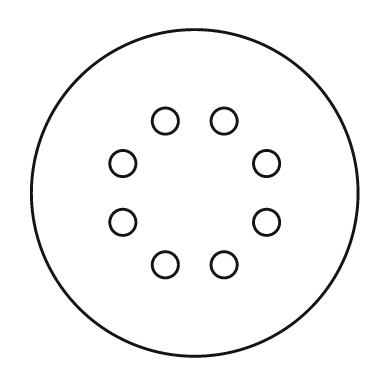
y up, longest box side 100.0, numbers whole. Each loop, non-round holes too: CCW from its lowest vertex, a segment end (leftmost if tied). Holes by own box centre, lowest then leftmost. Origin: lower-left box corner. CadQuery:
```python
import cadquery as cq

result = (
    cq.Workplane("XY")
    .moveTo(50.0, 50.0)
    .circle(50.0)
    .moveTo(41.0, 28.0)
    .circle(4.0)
    .moveTo(59.0, 28.0)
    .circle(4.0)
    .moveTo(28.0, 41.0)
    .circle(4.0)
    .moveTo(72.0, 41.0)
    .circle(4.0)
    .moveTo(28.0, 59.0)
    .circle(4.0)
    .moveTo(72.0, 59.0)
    .circle(4.0)
    .moveTo(41.0, 72.0)
    .circle(4.0)
    .moveTo(59.0, 72.0)
    .circle(4.0)
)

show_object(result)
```